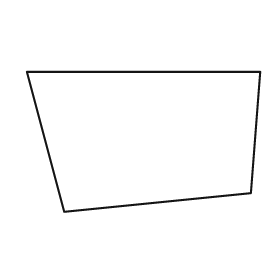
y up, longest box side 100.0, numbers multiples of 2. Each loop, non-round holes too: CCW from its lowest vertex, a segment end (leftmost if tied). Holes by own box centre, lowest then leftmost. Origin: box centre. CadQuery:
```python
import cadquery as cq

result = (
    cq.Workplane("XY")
    .moveTo(-34.0, -30.0)
    .lineTo(46.0, -22.0)
    .lineTo(50.0, 30.0)
    .lineTo(-50.0, 30.0)
    .close()
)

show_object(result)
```